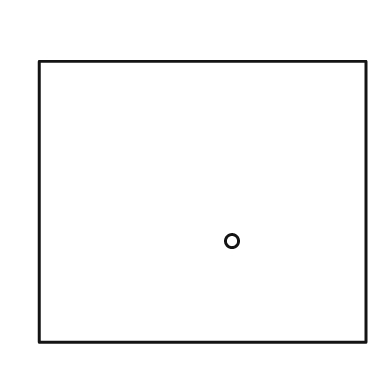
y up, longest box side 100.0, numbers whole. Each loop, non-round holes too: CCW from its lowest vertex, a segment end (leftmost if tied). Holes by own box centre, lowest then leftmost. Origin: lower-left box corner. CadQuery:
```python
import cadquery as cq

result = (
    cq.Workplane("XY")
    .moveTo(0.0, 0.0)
    .lineTo(100.0, 0.0)
    .lineTo(100.0, 86.0)
    .lineTo(0.0, 86.0)
    .close()
    .moveTo(59.0, 31.0)
    .circle(2.0)
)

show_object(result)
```